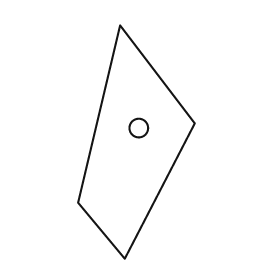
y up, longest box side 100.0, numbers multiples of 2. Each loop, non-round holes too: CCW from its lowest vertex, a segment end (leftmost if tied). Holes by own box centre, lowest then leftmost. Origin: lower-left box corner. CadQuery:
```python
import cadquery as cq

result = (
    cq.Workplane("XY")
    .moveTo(20.0, 0.0)
    .lineTo(50.0, 58.0)
    .lineTo(18.0, 100.0)
    .lineTo(0.0, 24.0)
    .close()
    .moveTo(26.0, 56.0)
    .circle(4.0)
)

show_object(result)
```